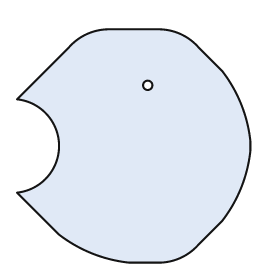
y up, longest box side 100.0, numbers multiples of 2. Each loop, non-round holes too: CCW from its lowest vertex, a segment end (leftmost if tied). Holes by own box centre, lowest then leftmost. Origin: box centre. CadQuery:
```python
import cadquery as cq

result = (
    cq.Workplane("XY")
    .moveTo(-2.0, -50.0)
    .lineTo(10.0, -50.0)
    .threePointArc((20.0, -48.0), (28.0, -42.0))
    .lineTo(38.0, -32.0)
    .threePointArc((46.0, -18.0), (50.0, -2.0))
    .lineTo(50.0, 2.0)
    .threePointArc((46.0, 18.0), (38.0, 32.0))
    .lineTo(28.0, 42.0)
    .threePointArc((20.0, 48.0), (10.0, 50.0))
    .lineTo(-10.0, 50.0)
    .threePointArc((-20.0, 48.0), (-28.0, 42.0))
    .lineTo(-50.0, 20.0)
    .threePointArc((-32.0, 0.0), (-50.0, -20.0))
    .lineTo(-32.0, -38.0)
    .threePointArc((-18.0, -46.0), (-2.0, -50.0))
    .close()
    .moveTo(6.0, 26.0)
    .circle(2.0)
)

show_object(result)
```